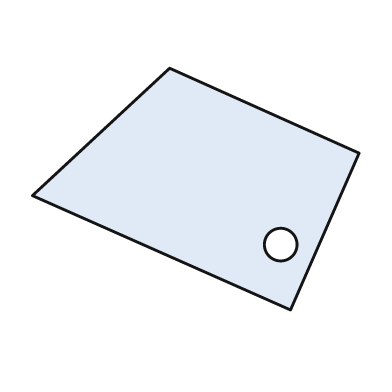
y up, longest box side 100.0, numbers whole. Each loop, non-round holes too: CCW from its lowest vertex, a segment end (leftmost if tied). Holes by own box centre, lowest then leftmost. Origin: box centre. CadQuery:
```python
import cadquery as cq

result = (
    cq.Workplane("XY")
    .moveTo(29.0, -37.0)
    .lineTo(50.0, 11.0)
    .lineTo(-8.0, 37.0)
    .lineTo(-50.0, -2.0)
    .close()
    .moveTo(26.0, -17.0)
    .circle(5.0)
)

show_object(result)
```